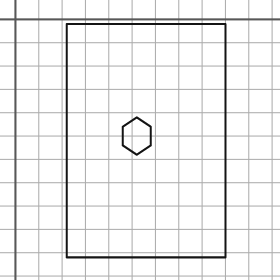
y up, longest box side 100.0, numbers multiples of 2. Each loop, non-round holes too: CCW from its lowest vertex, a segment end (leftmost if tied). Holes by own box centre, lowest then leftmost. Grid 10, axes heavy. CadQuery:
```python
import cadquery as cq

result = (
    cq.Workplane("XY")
    .moveTo(22.0, -102.0)
    .lineTo(90.0, -102.0)
    .lineTo(90.0, -2.0)
    .lineTo(22.0, -2.0)
    .close()
    .moveTo(52.0, -58.0)
    .lineTo(58.0, -54.0)
    .lineTo(58.0, -46.0)
    .lineTo(52.0, -42.0)
    .lineTo(46.0, -46.0)
    .lineTo(46.0, -54.0)
    .close()
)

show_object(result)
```